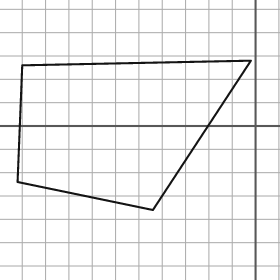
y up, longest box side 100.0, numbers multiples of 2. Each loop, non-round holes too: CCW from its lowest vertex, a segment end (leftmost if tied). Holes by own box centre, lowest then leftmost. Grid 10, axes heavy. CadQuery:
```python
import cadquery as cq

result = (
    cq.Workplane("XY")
    .moveTo(-44.0, -36.0)
    .lineTo(-2.0, 28.0)
    .lineTo(-100.0, 26.0)
    .lineTo(-102.0, -24.0)
    .close()
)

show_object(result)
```